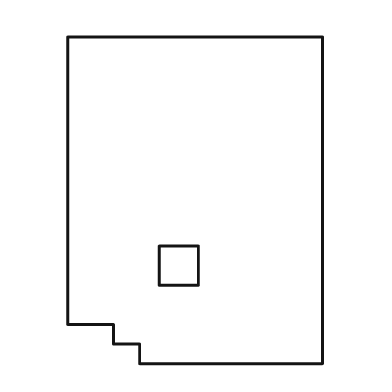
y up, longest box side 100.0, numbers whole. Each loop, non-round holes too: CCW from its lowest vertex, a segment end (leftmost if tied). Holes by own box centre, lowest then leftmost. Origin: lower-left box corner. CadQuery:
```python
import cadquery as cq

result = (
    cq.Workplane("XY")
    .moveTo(22.0, 0.0)
    .lineTo(78.0, 0.0)
    .lineTo(78.0, 100.0)
    .lineTo(0.0, 100.0)
    .lineTo(0.0, 12.0)
    .lineTo(14.0, 12.0)
    .lineTo(14.0, 6.0)
    .lineTo(22.0, 6.0)
    .close()
    .moveTo(28.0, 24.0)
    .lineTo(40.0, 24.0)
    .lineTo(40.0, 36.0)
    .lineTo(28.0, 36.0)
    .close()
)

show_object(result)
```